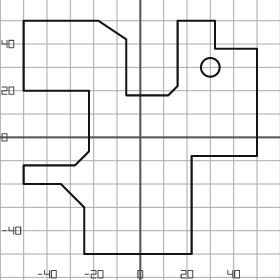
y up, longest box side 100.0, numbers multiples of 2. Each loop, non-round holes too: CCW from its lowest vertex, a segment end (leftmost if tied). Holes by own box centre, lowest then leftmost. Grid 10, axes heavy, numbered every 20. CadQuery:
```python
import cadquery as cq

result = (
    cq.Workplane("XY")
    .moveTo(-24.0, -50.0)
    .lineTo(22.0, -50.0)
    .lineTo(22.0, -8.0)
    .lineTo(50.0, -8.0)
    .lineTo(50.0, 38.0)
    .lineTo(32.0, 38.0)
    .lineTo(32.0, 50.0)
    .lineTo(16.0, 50.0)
    .lineTo(16.0, 22.0)
    .lineTo(12.0, 18.0)
    .lineTo(-6.0, 18.0)
    .lineTo(-6.0, 42.0)
    .lineTo(-18.0, 50.0)
    .lineTo(-50.0, 50.0)
    .lineTo(-50.0, 20.0)
    .lineTo(-22.0, 20.0)
    .lineTo(-22.0, -6.0)
    .lineTo(-28.0, -12.0)
    .lineTo(-50.0, -12.0)
    .lineTo(-50.0, -20.0)
    .lineTo(-34.0, -20.0)
    .lineTo(-24.0, -30.0)
    .close()
    .moveTo(30.0, 30.0)
    .circle(4.0)
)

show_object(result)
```